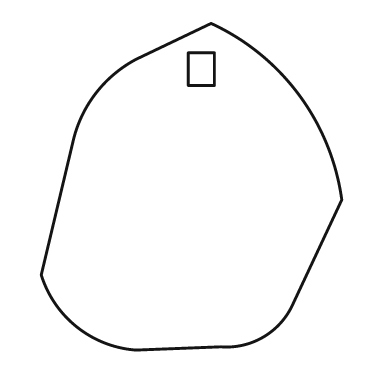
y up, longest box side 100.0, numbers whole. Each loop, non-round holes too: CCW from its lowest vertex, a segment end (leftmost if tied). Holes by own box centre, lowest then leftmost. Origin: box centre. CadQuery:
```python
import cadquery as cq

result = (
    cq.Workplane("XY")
    .moveTo(-17.0, -50.0)
    .lineTo(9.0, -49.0)
    .threePointArc((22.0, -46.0), (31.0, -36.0))
    .lineTo(46.0, -4.0)
    .threePointArc((33.0, 28.0), (6.0, 50.0))
    .lineTo(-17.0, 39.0)
    .threePointArc((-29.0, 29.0), (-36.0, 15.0))
    .lineTo(-46.0, -27.0)
    .threePointArc((-35.0, -43.0), (-17.0, -50.0))
    .close()
    .moveTo(-1.0, 31.0)
    .lineTo(7.0, 31.0)
    .lineTo(7.0, 41.0)
    .lineTo(-1.0, 41.0)
    .close()
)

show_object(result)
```